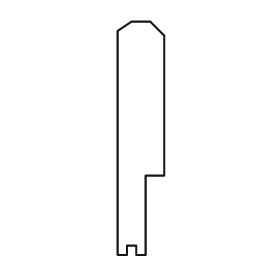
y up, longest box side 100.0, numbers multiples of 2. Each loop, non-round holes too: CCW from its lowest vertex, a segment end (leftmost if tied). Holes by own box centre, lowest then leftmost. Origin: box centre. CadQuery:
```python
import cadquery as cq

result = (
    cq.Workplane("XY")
    .moveTo(-10.0, -50.0)
    .lineTo(-6.0, -50.0)
    .lineTo(-6.0, -46.0)
    .lineTo(-2.0, -46.0)
    .lineTo(-2.0, -50.0)
    .lineTo(2.0, -50.0)
    .lineTo(2.0, -16.0)
    .lineTo(10.0, -16.0)
    .lineTo(10.0, 44.0)
    .lineTo(4.0, 50.0)
    .lineTo(-4.0, 50.0)
    .lineTo(-10.0, 46.0)
    .close()
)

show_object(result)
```